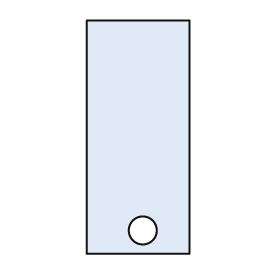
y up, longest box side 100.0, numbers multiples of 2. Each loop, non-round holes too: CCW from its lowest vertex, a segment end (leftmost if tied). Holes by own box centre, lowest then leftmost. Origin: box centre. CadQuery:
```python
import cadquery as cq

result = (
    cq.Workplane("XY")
    .moveTo(-22.0, -50.0)
    .lineTo(22.0, -50.0)
    .lineTo(22.0, 50.0)
    .lineTo(-22.0, 50.0)
    .close()
    .moveTo(2.0, -40.0)
    .circle(6.0)
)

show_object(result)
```